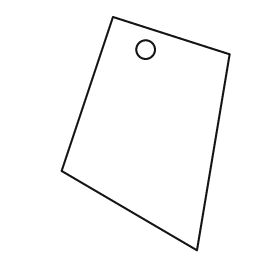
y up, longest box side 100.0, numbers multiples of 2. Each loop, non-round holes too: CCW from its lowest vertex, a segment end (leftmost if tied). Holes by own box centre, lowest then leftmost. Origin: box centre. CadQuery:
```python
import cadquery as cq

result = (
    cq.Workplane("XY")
    .moveTo(22.0, -50.0)
    .lineTo(36.0, 34.0)
    .lineTo(-14.0, 50.0)
    .lineTo(-36.0, -16.0)
    .close()
    .moveTo(0.0, 36.0)
    .circle(4.0)
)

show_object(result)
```